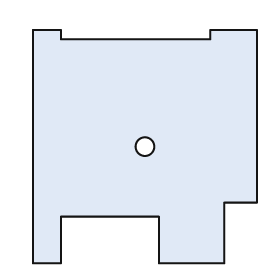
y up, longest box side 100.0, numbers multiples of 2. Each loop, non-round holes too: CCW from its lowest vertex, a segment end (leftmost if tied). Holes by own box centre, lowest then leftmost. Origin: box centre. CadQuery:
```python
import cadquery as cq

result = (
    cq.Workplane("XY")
    .moveTo(-48.0, -50.0)
    .lineTo(-36.0, -50.0)
    .lineTo(-36.0, -30.0)
    .lineTo(6.0, -30.0)
    .lineTo(6.0, -50.0)
    .lineTo(34.0, -50.0)
    .lineTo(34.0, -24.0)
    .lineTo(48.0, -24.0)
    .lineTo(48.0, 50.0)
    .lineTo(28.0, 50.0)
    .lineTo(28.0, 46.0)
    .lineTo(-36.0, 46.0)
    .lineTo(-36.0, 50.0)
    .lineTo(-48.0, 50.0)
    .close()
    .moveTo(0.0, 0.0)
    .circle(4.0)
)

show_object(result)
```